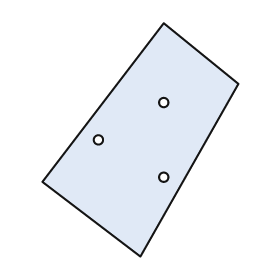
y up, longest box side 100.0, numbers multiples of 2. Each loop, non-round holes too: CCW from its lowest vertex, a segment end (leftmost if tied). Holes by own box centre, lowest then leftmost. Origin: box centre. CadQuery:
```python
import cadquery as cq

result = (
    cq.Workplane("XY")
    .moveTo(0.0, -50.0)
    .lineTo(42.0, 24.0)
    .lineTo(10.0, 50.0)
    .lineTo(-42.0, -18.0)
    .close()
    .moveTo(10.0, -16.0)
    .circle(2.0)
    .moveTo(-18.0, 0.0)
    .circle(2.0)
    .moveTo(10.0, 16.0)
    .circle(2.0)
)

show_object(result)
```